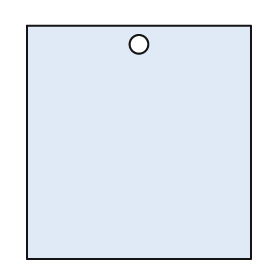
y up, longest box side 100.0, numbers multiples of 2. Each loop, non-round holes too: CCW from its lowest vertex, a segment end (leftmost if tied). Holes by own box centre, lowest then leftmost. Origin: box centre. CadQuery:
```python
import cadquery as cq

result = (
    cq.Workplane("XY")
    .moveTo(-48.0, -50.0)
    .lineTo(48.0, -50.0)
    .lineTo(48.0, 50.0)
    .lineTo(-48.0, 50.0)
    .close()
    .moveTo(0.0, 42.0)
    .circle(4.0)
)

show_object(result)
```